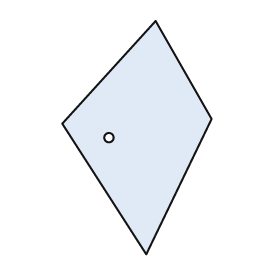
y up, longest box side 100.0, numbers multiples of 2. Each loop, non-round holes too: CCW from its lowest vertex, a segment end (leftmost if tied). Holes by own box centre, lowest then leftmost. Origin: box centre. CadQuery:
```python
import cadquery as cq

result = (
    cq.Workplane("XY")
    .moveTo(4.0, -50.0)
    .lineTo(32.0, 8.0)
    .lineTo(8.0, 50.0)
    .lineTo(-32.0, 6.0)
    .close()
    .moveTo(-12.0, 0.0)
    .circle(2.0)
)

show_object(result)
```